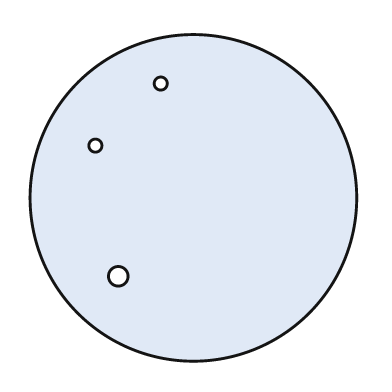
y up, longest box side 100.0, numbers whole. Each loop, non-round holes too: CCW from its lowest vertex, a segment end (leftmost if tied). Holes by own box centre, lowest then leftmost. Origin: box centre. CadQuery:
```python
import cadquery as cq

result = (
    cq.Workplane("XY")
    .moveTo(0.0, 0.0)
    .circle(50.0)
    .moveTo(-23.0, -24.0)
    .circle(3.0)
    .moveTo(-30.0, 16.0)
    .circle(2.0)
    .moveTo(-10.0, 35.0)
    .circle(2.0)
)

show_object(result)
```